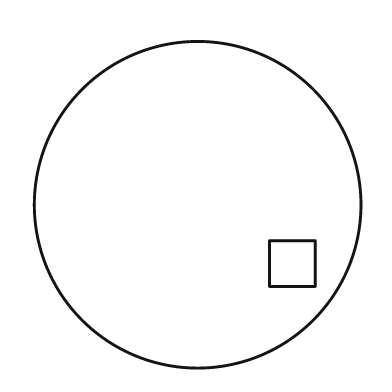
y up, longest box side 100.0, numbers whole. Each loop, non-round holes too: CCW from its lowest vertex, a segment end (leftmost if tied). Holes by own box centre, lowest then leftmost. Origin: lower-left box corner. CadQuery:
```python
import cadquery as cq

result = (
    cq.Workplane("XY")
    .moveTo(50.0, 50.0)
    .circle(50.0)
    .moveTo(72.0, 25.0)
    .lineTo(86.0, 25.0)
    .lineTo(86.0, 39.0)
    .lineTo(72.0, 39.0)
    .close()
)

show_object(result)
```